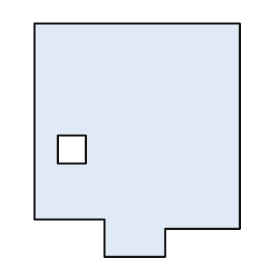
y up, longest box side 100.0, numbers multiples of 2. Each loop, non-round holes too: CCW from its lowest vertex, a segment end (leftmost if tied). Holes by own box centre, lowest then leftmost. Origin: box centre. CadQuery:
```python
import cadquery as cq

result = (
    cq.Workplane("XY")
    .moveTo(-14.0, -50.0)
    .lineTo(12.0, -50.0)
    .lineTo(12.0, -38.0)
    .lineTo(44.0, -38.0)
    .lineTo(44.0, 50.0)
    .lineTo(-44.0, 50.0)
    .lineTo(-44.0, -34.0)
    .lineTo(-14.0, -34.0)
    .close()
    .moveTo(-34.0, -10.0)
    .lineTo(-22.0, -10.0)
    .lineTo(-22.0, 2.0)
    .lineTo(-34.0, 2.0)
    .close()
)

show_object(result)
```